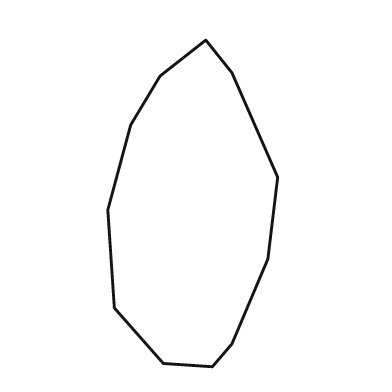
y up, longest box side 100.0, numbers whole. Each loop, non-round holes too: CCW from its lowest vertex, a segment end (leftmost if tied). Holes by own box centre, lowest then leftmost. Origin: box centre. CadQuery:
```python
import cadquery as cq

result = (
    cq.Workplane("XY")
    .moveTo(6.0, -50.0)
    .lineTo(12.0, -43.0)
    .lineTo(23.0, -17.0)
    .lineTo(26.0, 8.0)
    .lineTo(12.0, 40.0)
    .lineTo(4.0, 50.0)
    .lineTo(-10.0, 39.0)
    .lineTo(-19.0, 24.0)
    .lineTo(-26.0, -2.0)
    .lineTo(-24.0, -32.0)
    .lineTo(-9.0, -49.0)
    .close()
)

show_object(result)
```